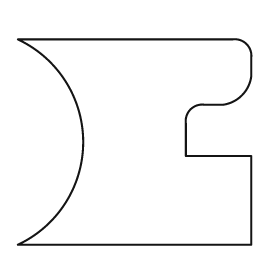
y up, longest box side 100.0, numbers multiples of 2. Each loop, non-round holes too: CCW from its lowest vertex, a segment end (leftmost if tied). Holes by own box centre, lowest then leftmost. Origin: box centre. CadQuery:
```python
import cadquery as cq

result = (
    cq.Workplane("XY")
    .moveTo(-50.0, -44.0)
    .lineTo(50.0, -44.0)
    .lineTo(50.0, -6.0)
    .lineTo(22.0, -6.0)
    .lineTo(22.0, 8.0)
    .threePointArc((24.0, 14.0), (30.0, 16.0))
    .lineTo(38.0, 16.0)
    .threePointArc((46.0, 20.0), (50.0, 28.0))
    .lineTo(50.0, 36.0)
    .threePointArc((48.0, 42.0), (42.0, 44.0))
    .lineTo(-50.0, 44.0)
    .threePointArc((-22.0, 0.0), (-50.0, -44.0))
    .close()
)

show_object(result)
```